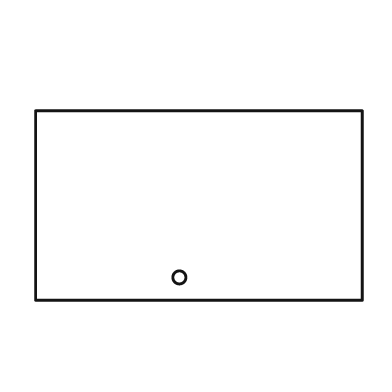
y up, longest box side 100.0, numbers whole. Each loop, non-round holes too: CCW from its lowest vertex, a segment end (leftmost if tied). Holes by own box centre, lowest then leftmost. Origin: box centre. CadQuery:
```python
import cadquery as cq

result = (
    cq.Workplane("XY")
    .moveTo(-50.0, -29.0)
    .lineTo(50.0, -29.0)
    .lineTo(50.0, 29.0)
    .lineTo(-50.0, 29.0)
    .close()
    .moveTo(-6.0, -22.0)
    .circle(2.0)
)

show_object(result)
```